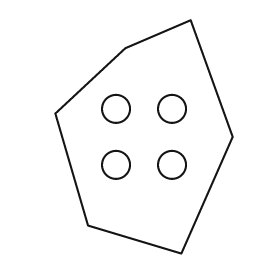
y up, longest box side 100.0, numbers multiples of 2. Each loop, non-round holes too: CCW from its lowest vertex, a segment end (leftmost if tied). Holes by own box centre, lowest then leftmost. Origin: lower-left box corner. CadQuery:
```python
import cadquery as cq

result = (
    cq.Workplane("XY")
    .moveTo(54.0, 0.0)
    .lineTo(76.0, 50.0)
    .lineTo(58.0, 100.0)
    .lineTo(30.0, 88.0)
    .lineTo(0.0, 60.0)
    .lineTo(14.0, 12.0)
    .close()
    .moveTo(26.0, 38.0)
    .circle(6.0)
    .moveTo(50.0, 38.0)
    .circle(6.0)
    .moveTo(26.0, 62.0)
    .circle(6.0)
    .moveTo(50.0, 62.0)
    .circle(6.0)
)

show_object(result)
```